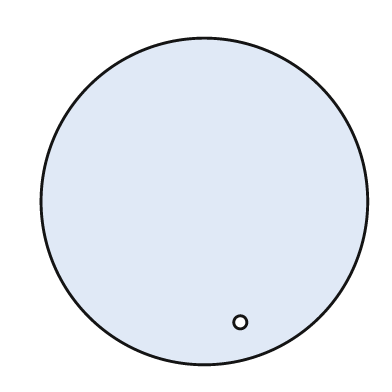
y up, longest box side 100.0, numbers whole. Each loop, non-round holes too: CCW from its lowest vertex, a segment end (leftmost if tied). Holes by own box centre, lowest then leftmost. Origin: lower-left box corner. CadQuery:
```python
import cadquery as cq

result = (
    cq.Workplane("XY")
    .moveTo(50.0, 50.0)
    .circle(50.0)
    .moveTo(61.0, 13.0)
    .circle(2.0)
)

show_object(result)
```